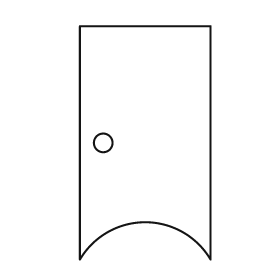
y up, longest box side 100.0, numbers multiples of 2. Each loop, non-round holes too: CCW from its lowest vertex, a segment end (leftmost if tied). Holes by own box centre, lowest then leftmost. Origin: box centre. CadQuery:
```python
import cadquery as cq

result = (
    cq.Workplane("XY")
    .moveTo(-28.0, -50.0)
    .threePointArc((0.0, -34.0), (28.0, -50.0))
    .lineTo(28.0, 50.0)
    .lineTo(-28.0, 50.0)
    .close()
    .moveTo(-18.0, 0.0)
    .circle(4.0)
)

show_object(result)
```